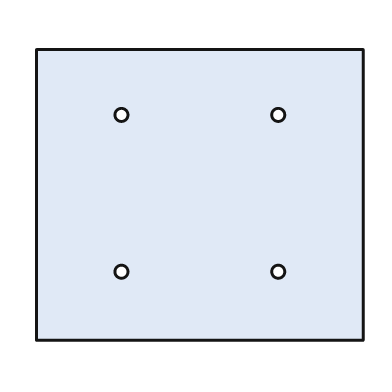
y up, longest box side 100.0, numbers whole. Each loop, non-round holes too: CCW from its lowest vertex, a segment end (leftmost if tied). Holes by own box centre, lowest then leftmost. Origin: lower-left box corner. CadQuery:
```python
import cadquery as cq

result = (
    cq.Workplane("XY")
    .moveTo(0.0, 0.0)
    .lineTo(100.0, 0.0)
    .lineTo(100.0, 89.0)
    .lineTo(0.0, 89.0)
    .close()
    .moveTo(26.0, 21.0)
    .circle(2.0)
    .moveTo(74.0, 21.0)
    .circle(2.0)
    .moveTo(26.0, 69.0)
    .circle(2.0)
    .moveTo(74.0, 69.0)
    .circle(2.0)
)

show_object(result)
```